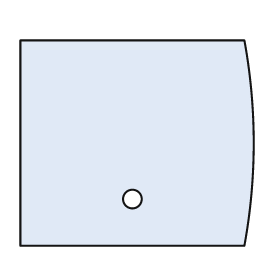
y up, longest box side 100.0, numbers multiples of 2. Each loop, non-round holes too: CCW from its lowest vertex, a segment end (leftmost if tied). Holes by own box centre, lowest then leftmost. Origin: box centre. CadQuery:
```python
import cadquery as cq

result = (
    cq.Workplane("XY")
    .moveTo(-50.0, -44.0)
    .lineTo(46.0, -44.0)
    .threePointArc((50.0, 0.0), (46.0, 44.0))
    .lineTo(-50.0, 44.0)
    .close()
    .moveTo(-2.0, -24.0)
    .circle(4.0)
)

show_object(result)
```